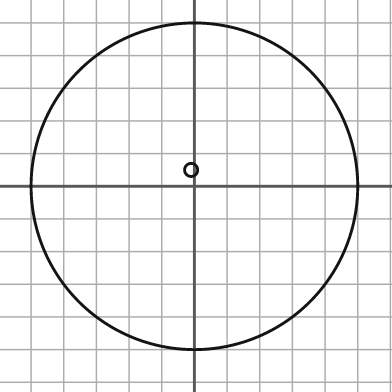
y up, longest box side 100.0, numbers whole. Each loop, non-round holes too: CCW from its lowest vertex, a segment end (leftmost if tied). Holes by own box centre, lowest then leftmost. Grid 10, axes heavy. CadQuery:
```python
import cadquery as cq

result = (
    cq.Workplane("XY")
    .moveTo(0.0, 0.0)
    .circle(50.0)
    .moveTo(-1.0, 5.0)
    .circle(2.0)
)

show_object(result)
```